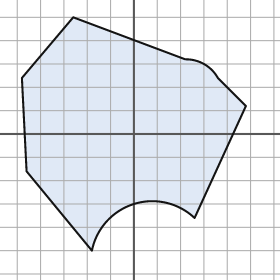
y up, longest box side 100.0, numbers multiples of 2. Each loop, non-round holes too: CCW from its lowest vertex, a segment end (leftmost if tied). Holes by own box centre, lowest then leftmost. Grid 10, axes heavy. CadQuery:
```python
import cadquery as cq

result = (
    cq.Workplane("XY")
    .moveTo(-18.0, -50.0)
    .threePointArc((0.0, -30.0), (26.0, -36.0))
    .lineTo(48.0, 12.0)
    .lineTo(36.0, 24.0)
    .threePointArc((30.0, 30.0), (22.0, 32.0))
    .lineTo(-26.0, 50.0)
    .lineTo(-48.0, 24.0)
    .lineTo(-46.0, -16.0)
    .close()
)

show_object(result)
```